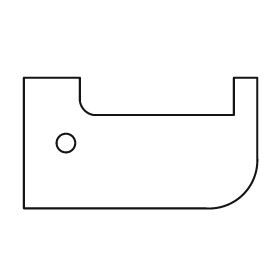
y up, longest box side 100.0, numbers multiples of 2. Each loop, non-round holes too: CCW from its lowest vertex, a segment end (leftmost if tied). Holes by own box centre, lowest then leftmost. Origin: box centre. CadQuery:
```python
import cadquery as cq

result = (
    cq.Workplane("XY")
    .moveTo(-50.0, -28.0)
    .lineTo(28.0, -28.0)
    .threePointArc((44.0, -22.0), (50.0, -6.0))
    .lineTo(50.0, 28.0)
    .lineTo(40.0, 28.0)
    .lineTo(40.0, 12.0)
    .lineTo(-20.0, 12.0)
    .threePointArc((-24.0, 14.0), (-26.0, 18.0))
    .lineTo(-26.0, 28.0)
    .lineTo(-50.0, 28.0)
    .close()
    .moveTo(-32.0, 0.0)
    .circle(4.0)
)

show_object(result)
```